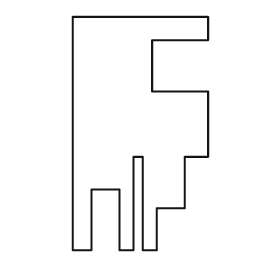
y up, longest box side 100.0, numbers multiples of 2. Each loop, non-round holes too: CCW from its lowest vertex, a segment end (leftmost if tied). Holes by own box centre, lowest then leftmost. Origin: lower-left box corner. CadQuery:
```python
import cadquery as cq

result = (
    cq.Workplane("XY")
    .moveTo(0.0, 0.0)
    .lineTo(8.0, 0.0)
    .lineTo(8.0, 26.0)
    .lineTo(20.0, 26.0)
    .lineTo(20.0, 0.0)
    .lineTo(26.0, 0.0)
    .lineTo(26.0, 40.0)
    .lineTo(30.0, 40.0)
    .lineTo(30.0, 0.0)
    .lineTo(36.0, 0.0)
    .lineTo(36.0, 18.0)
    .lineTo(48.0, 18.0)
    .lineTo(48.0, 40.0)
    .lineTo(58.0, 40.0)
    .lineTo(58.0, 68.0)
    .lineTo(34.0, 68.0)
    .lineTo(34.0, 90.0)
    .lineTo(58.0, 90.0)
    .lineTo(58.0, 100.0)
    .lineTo(0.0, 100.0)
    .close()
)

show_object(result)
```